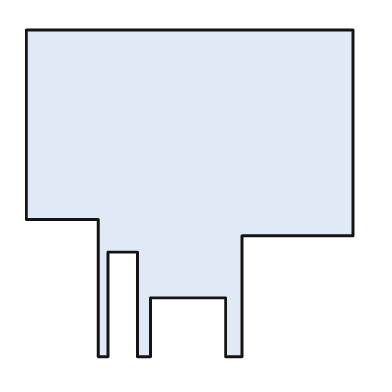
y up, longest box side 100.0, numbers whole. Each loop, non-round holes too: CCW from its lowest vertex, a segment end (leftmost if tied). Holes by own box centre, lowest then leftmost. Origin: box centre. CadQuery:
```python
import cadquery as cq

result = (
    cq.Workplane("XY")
    .moveTo(-28.0, -50.0)
    .lineTo(-25.0, -50.0)
    .lineTo(-25.0, -18.0)
    .lineTo(-16.0, -18.0)
    .lineTo(-16.0, -50.0)
    .lineTo(-12.0, -50.0)
    .lineTo(-12.0, -32.0)
    .lineTo(11.0, -32.0)
    .lineTo(11.0, -50.0)
    .lineTo(16.0, -50.0)
    .lineTo(16.0, -13.0)
    .lineTo(50.0, -13.0)
    .lineTo(50.0, 50.0)
    .lineTo(-50.0, 50.0)
    .lineTo(-50.0, -8.0)
    .lineTo(-28.0, -8.0)
    .close()
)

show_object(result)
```